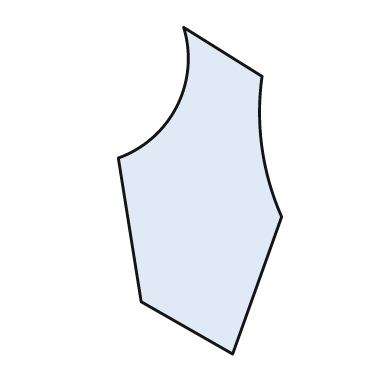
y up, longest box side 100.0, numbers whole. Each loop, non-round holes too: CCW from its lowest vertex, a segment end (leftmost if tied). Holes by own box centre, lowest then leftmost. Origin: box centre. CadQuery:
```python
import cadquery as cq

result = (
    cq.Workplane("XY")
    .moveTo(10.0, -50.0)
    .lineTo(25.0, -8.0)
    .threePointArc((19.0, 13.0), (19.0, 35.0))
    .lineTo(-5.0, 50.0)
    .threePointArc((-7.0, 26.0), (-25.0, 10.0))
    .lineTo(-18.0, -34.0)
    .close()
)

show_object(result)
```